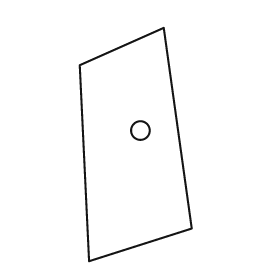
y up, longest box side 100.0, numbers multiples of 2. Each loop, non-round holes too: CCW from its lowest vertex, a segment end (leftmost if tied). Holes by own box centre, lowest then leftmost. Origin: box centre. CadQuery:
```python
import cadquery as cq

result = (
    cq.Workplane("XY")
    .moveTo(-20.0, -50.0)
    .lineTo(24.0, -36.0)
    .lineTo(12.0, 50.0)
    .lineTo(-24.0, 34.0)
    .close()
    .moveTo(2.0, 6.0)
    .circle(4.0)
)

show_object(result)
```